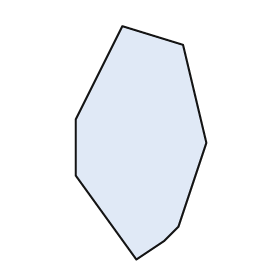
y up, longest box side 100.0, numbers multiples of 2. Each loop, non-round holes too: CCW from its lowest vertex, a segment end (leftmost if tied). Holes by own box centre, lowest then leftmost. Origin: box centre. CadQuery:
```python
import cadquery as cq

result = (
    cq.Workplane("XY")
    .moveTo(-2.0, -50.0)
    .lineTo(10.0, -42.0)
    .lineTo(16.0, -36.0)
    .lineTo(28.0, 0.0)
    .lineTo(18.0, 42.0)
    .lineTo(-8.0, 50.0)
    .lineTo(-28.0, 10.0)
    .lineTo(-28.0, -14.0)
    .close()
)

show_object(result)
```